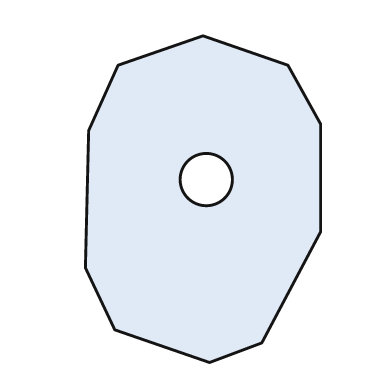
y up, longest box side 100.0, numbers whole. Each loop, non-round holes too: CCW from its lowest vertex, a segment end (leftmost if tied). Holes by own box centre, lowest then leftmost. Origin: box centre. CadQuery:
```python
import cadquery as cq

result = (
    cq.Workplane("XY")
    .moveTo(2.0, -50.0)
    .lineTo(18.0, -44.0)
    .lineTo(36.0, -10.0)
    .lineTo(36.0, 23.0)
    .lineTo(26.0, 41.0)
    .lineTo(0.0, 50.0)
    .lineTo(-26.0, 41.0)
    .lineTo(-35.0, 21.0)
    .lineTo(-36.0, -21.0)
    .lineTo(-27.0, -40.0)
    .close()
    .moveTo(1.0, 6.0)
    .circle(8.0)
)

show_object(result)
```